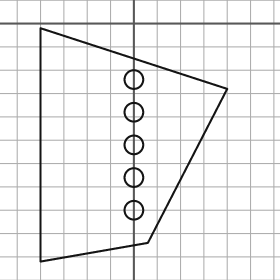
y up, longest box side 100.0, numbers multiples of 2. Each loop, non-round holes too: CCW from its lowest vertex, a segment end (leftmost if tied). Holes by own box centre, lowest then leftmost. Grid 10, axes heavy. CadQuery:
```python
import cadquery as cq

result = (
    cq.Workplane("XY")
    .moveTo(-40.0, -102.0)
    .lineTo(6.0, -94.0)
    .lineTo(40.0, -28.0)
    .lineTo(-40.0, -2.0)
    .close()
    .moveTo(0.0, -80.0)
    .circle(4.0)
    .moveTo(0.0, -66.0)
    .circle(4.0)
    .moveTo(0.0, -52.0)
    .circle(4.0)
    .moveTo(0.0, -38.0)
    .circle(4.0)
    .moveTo(0.0, -24.0)
    .circle(4.0)
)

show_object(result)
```